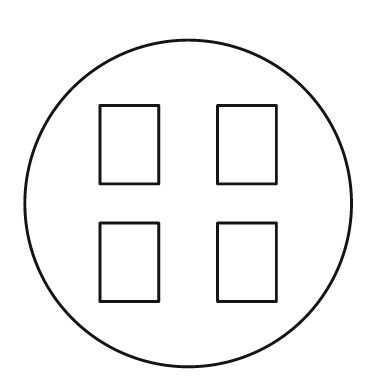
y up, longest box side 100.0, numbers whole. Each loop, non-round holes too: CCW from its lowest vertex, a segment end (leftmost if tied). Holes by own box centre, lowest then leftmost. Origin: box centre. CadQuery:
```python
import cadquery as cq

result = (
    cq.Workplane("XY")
    .moveTo(0.0, 0.0)
    .circle(50.0)
    .moveTo(-27.0, -30.0)
    .lineTo(-9.0, -30.0)
    .lineTo(-9.0, -6.0)
    .lineTo(-27.0, -6.0)
    .close()
    .moveTo(9.0, -30.0)
    .lineTo(27.0, -30.0)
    .lineTo(27.0, -6.0)
    .lineTo(9.0, -6.0)
    .close()
    .moveTo(-27.0, 6.0)
    .lineTo(-9.0, 6.0)
    .lineTo(-9.0, 30.0)
    .lineTo(-27.0, 30.0)
    .close()
    .moveTo(9.0, 6.0)
    .lineTo(27.0, 6.0)
    .lineTo(27.0, 30.0)
    .lineTo(9.0, 30.0)
    .close()
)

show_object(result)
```